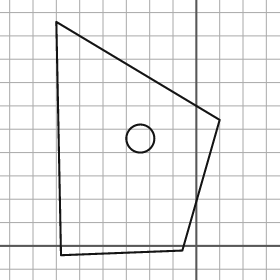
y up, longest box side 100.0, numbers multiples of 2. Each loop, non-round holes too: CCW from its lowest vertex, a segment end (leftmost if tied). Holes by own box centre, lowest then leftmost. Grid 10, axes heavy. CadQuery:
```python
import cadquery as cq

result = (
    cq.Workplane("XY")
    .moveTo(-58.0, -4.0)
    .lineTo(-6.0, -2.0)
    .lineTo(10.0, 54.0)
    .lineTo(-60.0, 96.0)
    .close()
    .moveTo(-24.0, 46.0)
    .circle(6.0)
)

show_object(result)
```